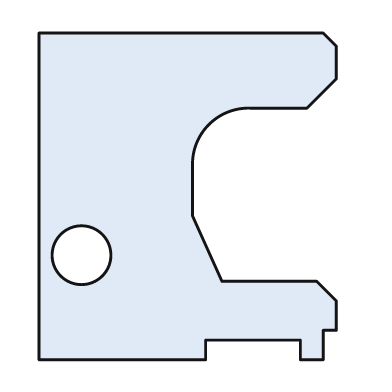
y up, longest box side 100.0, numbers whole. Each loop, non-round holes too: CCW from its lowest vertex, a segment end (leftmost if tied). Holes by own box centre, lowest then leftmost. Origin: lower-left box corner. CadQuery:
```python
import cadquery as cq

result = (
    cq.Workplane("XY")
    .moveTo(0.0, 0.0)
    .lineTo(51.0, 0.0)
    .lineTo(51.0, 6.0)
    .lineTo(80.0, 6.0)
    .lineTo(80.0, 0.0)
    .lineTo(87.0, 0.0)
    .lineTo(87.0, 9.0)
    .lineTo(91.0, 9.0)
    .lineTo(91.0, 18.0)
    .lineTo(85.0, 24.0)
    .lineTo(56.0, 24.0)
    .lineTo(47.0, 44.0)
    .lineTo(47.0, 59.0)
    .threePointArc((52.0, 72.0), (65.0, 77.0))
    .lineTo(82.0, 77.0)
    .lineTo(91.0, 86.0)
    .lineTo(91.0, 96.0)
    .lineTo(87.0, 100.0)
    .lineTo(0.0, 100.0)
    .close()
    .moveTo(13.0, 32.0)
    .circle(9.0)
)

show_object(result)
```